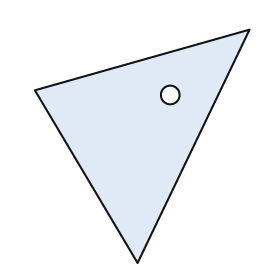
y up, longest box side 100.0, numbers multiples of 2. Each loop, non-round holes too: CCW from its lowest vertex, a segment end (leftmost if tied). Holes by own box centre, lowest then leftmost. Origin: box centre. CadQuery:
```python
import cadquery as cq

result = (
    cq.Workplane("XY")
    .moveTo(-2.0, -50.0)
    .lineTo(46.0, 50.0)
    .lineTo(-46.0, 24.0)
    .close()
    .moveTo(12.0, 22.0)
    .circle(4.0)
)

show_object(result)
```